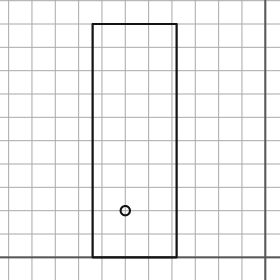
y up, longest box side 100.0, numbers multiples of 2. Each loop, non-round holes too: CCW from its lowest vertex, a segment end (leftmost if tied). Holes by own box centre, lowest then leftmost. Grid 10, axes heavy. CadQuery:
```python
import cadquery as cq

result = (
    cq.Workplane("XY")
    .moveTo(-74.0, 0.0)
    .lineTo(-38.0, 0.0)
    .lineTo(-38.0, 100.0)
    .lineTo(-74.0, 100.0)
    .close()
    .moveTo(-60.0, 20.0)
    .circle(2.0)
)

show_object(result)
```